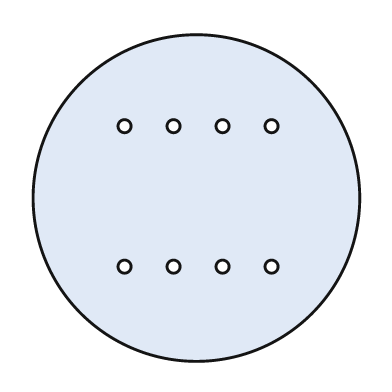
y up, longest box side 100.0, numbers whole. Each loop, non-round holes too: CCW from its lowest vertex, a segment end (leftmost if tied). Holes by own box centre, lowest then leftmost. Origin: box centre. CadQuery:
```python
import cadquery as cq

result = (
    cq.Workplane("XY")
    .moveTo(0.0, 0.0)
    .circle(50.0)
    .moveTo(-22.0, -21.0)
    .circle(2.0)
    .moveTo(-7.0, -21.0)
    .circle(2.0)
    .moveTo(8.0, -21.0)
    .circle(2.0)
    .moveTo(23.0, -21.0)
    .circle(2.0)
    .moveTo(-22.0, 22.0)
    .circle(2.0)
    .moveTo(-7.0, 22.0)
    .circle(2.0)
    .moveTo(8.0, 22.0)
    .circle(2.0)
    .moveTo(23.0, 22.0)
    .circle(2.0)
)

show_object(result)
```